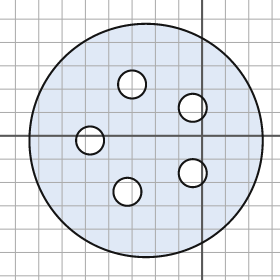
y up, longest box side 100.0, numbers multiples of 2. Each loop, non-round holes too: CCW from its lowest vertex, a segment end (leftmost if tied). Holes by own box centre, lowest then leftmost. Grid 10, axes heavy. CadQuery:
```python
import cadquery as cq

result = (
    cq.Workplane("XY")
    .moveTo(-24.0, -2.0)
    .circle(50.0)
    .moveTo(-32.0, -24.0)
    .circle(6.0)
    .moveTo(-4.0, -16.0)
    .circle(6.0)
    .moveTo(-48.0, -2.0)
    .circle(6.0)
    .moveTo(-4.0, 12.0)
    .circle(6.0)
    .moveTo(-30.0, 22.0)
    .circle(6.0)
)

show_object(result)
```